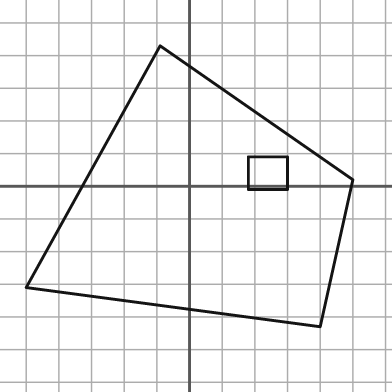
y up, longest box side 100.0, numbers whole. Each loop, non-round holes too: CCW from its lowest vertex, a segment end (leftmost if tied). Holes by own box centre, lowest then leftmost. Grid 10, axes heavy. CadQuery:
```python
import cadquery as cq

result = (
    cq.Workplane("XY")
    .moveTo(40.0, -43.0)
    .lineTo(50.0, 2.0)
    .lineTo(-9.0, 43.0)
    .lineTo(-50.0, -31.0)
    .close()
    .moveTo(18.0, -1.0)
    .lineTo(30.0, -1.0)
    .lineTo(30.0, 9.0)
    .lineTo(18.0, 9.0)
    .close()
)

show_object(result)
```